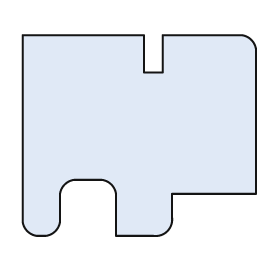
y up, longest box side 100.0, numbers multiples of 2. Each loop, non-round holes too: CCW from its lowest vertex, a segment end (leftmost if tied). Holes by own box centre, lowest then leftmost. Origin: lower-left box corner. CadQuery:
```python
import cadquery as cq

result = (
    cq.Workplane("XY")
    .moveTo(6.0, 0.0)
    .lineTo(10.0, 0.0)
    .threePointArc((14.0, 2.0), (16.0, 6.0))
    .lineTo(16.0, 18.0)
    .threePointArc((18.0, 22.0), (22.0, 24.0))
    .lineTo(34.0, 24.0)
    .threePointArc((38.0, 22.0), (40.0, 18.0))
    .lineTo(40.0, 0.0)
    .lineTo(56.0, 0.0)
    .threePointArc((62.0, 2.0), (64.0, 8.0))
    .lineTo(64.0, 18.0)
    .lineTo(100.0, 18.0)
    .lineTo(100.0, 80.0)
    .threePointArc((98.0, 84.0), (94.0, 86.0))
    .lineTo(60.0, 86.0)
    .lineTo(60.0, 70.0)
    .lineTo(52.0, 70.0)
    .lineTo(52.0, 86.0)
    .lineTo(0.0, 86.0)
    .lineTo(0.0, 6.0)
    .threePointArc((2.0, 2.0), (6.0, 0.0))
    .close()
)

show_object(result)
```